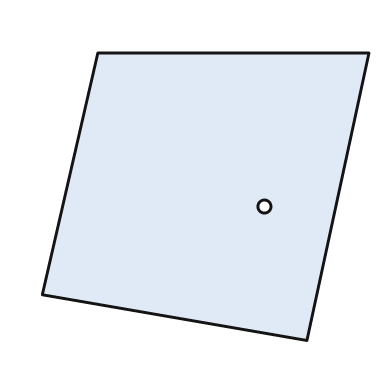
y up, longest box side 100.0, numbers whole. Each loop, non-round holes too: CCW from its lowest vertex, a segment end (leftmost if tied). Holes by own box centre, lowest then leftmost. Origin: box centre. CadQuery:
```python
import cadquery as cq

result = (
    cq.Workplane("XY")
    .moveTo(31.0, -44.0)
    .lineTo(50.0, 44.0)
    .lineTo(-33.0, 44.0)
    .lineTo(-50.0, -30.0)
    .close()
    .moveTo(18.0, -3.0)
    .circle(2.0)
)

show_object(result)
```